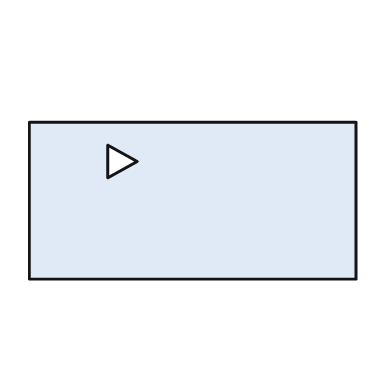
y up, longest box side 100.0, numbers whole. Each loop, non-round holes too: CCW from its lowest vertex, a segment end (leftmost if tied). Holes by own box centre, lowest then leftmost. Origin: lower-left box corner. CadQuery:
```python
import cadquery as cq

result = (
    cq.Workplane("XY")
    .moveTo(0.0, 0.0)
    .lineTo(100.0, 0.0)
    .lineTo(100.0, 48.0)
    .lineTo(0.0, 48.0)
    .close()
    .moveTo(24.0, 31.0)
    .lineTo(33.0, 36.0)
    .lineTo(24.0, 41.0)
    .close()
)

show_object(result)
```